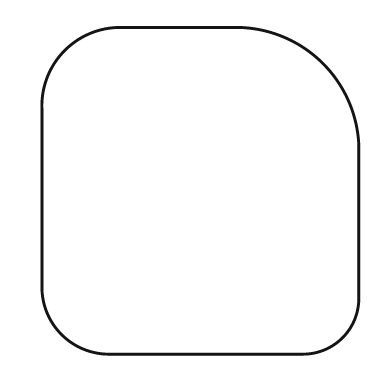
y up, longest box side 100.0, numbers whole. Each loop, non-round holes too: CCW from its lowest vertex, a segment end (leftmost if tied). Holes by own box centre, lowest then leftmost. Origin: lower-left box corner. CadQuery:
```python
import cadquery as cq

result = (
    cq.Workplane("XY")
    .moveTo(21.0, 0.0)
    .lineTo(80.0, 0.0)
    .threePointArc((92.0, 5.0), (97.0, 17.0))
    .lineTo(97.0, 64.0)
    .threePointArc((86.0, 89.0), (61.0, 100.0))
    .lineTo(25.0, 100.0)
    .threePointArc((7.0, 93.0), (0.0, 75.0))
    .lineTo(0.0, 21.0)
    .threePointArc((6.0, 6.0), (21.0, 0.0))
    .close()
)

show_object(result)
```